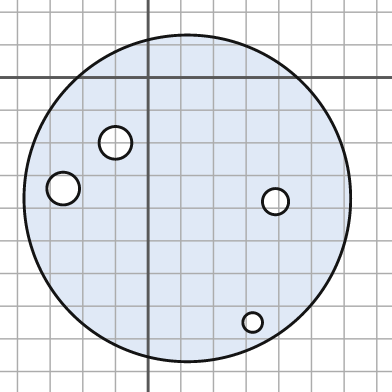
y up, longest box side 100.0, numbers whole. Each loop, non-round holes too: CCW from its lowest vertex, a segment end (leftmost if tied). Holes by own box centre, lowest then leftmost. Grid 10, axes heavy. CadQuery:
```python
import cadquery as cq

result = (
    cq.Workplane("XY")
    .moveTo(12.0, -37.0)
    .circle(50.0)
    .moveTo(32.0, -75.0)
    .circle(3.0)
    .moveTo(39.0, -38.0)
    .circle(4.0)
    .moveTo(-26.0, -34.0)
    .circle(5.0)
    .moveTo(-10.0, -20.0)
    .circle(5.0)
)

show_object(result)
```